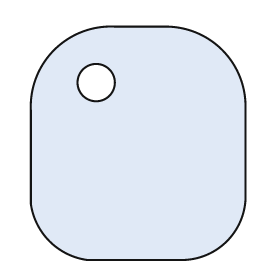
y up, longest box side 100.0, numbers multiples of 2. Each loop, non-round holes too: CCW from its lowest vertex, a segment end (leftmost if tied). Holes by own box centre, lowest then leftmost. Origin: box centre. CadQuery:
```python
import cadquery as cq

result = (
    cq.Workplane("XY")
    .moveTo(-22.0, -50.0)
    .lineTo(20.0, -50.0)
    .threePointArc((38.0, -42.0), (46.0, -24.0))
    .lineTo(46.0, 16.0)
    .threePointArc((36.0, 40.0), (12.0, 50.0))
    .lineTo(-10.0, 50.0)
    .threePointArc((-36.0, 40.0), (-46.0, 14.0))
    .lineTo(-46.0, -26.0)
    .threePointArc((-38.0, -42.0), (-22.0, -50.0))
    .close()
    .moveTo(-18.0, 26.0)
    .circle(8.0)
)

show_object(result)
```